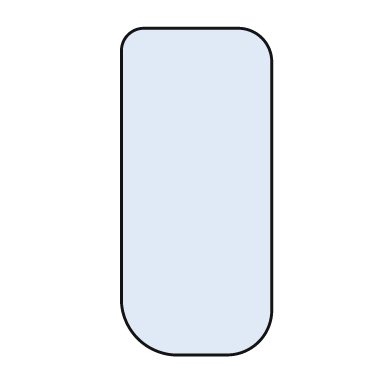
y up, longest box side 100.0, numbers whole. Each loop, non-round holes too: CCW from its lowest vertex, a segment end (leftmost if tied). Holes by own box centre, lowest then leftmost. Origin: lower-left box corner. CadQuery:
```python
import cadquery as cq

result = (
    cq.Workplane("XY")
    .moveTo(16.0, 0.0)
    .lineTo(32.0, 0.0)
    .threePointArc((42.0, 4.0), (46.0, 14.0))
    .lineTo(46.0, 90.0)
    .threePointArc((43.0, 97.0), (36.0, 100.0))
    .lineTo(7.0, 100.0)
    .threePointArc((2.0, 98.0), (0.0, 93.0))
    .lineTo(0.0, 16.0)
    .threePointArc((5.0, 5.0), (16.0, 0.0))
    .close()
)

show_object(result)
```